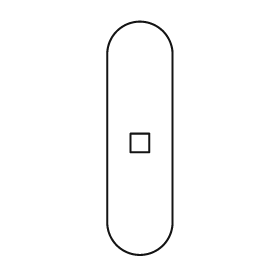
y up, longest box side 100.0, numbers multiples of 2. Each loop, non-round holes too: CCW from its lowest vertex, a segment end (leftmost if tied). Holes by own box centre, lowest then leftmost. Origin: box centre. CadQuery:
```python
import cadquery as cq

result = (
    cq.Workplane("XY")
    .moveTo(-14.0, -36.0)
    .threePointArc((0.0, -50.0), (14.0, -36.0))
    .lineTo(14.0, 36.0)
    .threePointArc((0.0, 50.0), (-14.0, 36.0))
    .close()
    .moveTo(-4.0, -6.0)
    .lineTo(4.0, -6.0)
    .lineTo(4.0, 2.0)
    .lineTo(-4.0, 2.0)
    .close()
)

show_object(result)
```